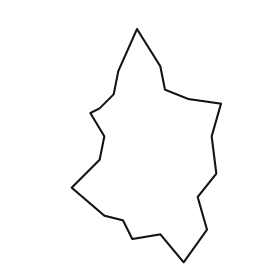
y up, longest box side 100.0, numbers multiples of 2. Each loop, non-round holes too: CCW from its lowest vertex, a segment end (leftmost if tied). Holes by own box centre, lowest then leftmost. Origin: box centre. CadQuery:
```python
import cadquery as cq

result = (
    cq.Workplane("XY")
    .moveTo(16.0, -50.0)
    .lineTo(26.0, -36.0)
    .lineTo(22.0, -22.0)
    .lineTo(30.0, -12.0)
    .lineTo(28.0, 4.0)
    .lineTo(32.0, 18.0)
    .lineTo(18.0, 20.0)
    .lineTo(8.0, 24.0)
    .lineTo(6.0, 34.0)
    .lineTo(-4.0, 50.0)
    .lineTo(-12.0, 32.0)
    .lineTo(-14.0, 22.0)
    .lineTo(-20.0, 16.0)
    .lineTo(-24.0, 14.0)
    .lineTo(-18.0, 4.0)
    .lineTo(-20.0, -6.0)
    .lineTo(-32.0, -18.0)
    .lineTo(-18.0, -30.0)
    .lineTo(-10.0, -32.0)
    .lineTo(-6.0, -40.0)
    .lineTo(6.0, -38.0)
    .close()
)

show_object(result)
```